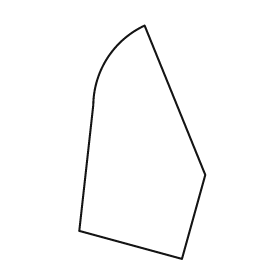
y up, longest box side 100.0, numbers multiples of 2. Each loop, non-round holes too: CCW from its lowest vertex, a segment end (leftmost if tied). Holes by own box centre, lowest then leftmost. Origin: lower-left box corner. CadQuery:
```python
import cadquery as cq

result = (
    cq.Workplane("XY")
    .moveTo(44.0, 0.0)
    .lineTo(54.0, 36.0)
    .lineTo(28.0, 100.0)
    .threePointArc((12.0, 86.0), (6.0, 66.0))
    .lineTo(0.0, 12.0)
    .close()
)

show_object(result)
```